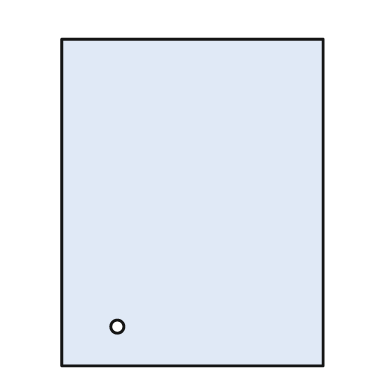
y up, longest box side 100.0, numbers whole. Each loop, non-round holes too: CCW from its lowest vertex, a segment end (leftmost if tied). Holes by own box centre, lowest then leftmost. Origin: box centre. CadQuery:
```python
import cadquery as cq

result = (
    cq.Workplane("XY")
    .moveTo(-40.0, -50.0)
    .lineTo(40.0, -50.0)
    .lineTo(40.0, 50.0)
    .lineTo(-40.0, 50.0)
    .close()
    .moveTo(-23.0, -38.0)
    .circle(2.0)
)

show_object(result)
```